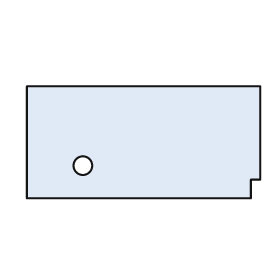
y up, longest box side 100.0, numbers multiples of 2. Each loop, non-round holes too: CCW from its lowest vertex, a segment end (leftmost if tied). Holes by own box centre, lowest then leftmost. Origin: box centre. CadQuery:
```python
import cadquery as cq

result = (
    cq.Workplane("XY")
    .moveTo(-50.0, -24.0)
    .lineTo(46.0, -24.0)
    .lineTo(46.0, -16.0)
    .lineTo(50.0, -16.0)
    .lineTo(50.0, 24.0)
    .lineTo(-50.0, 24.0)
    .close()
    .moveTo(-26.0, -10.0)
    .circle(4.0)
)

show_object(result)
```